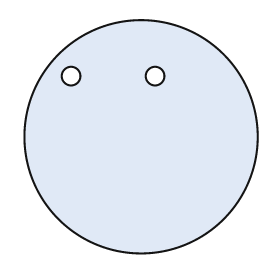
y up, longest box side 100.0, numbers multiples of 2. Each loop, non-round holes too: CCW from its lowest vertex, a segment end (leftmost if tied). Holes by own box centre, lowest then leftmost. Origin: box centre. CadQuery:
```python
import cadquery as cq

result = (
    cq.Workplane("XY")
    .moveTo(0.0, 0.0)
    .circle(50.0)
    .moveTo(-30.0, 26.0)
    .circle(4.0)
    .moveTo(6.0, 26.0)
    .circle(4.0)
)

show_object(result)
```